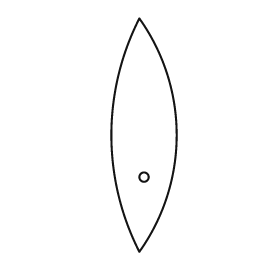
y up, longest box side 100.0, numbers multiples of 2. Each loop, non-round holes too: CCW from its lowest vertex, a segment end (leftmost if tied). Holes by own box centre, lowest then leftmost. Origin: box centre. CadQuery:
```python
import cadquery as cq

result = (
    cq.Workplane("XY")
    .moveTo(-2.0, -50.0)
    .threePointArc((14.0, 0.0), (-2.0, 50.0))
    .threePointArc((-14.0, 0.0), (-2.0, -50.0))
    .close()
    .moveTo(0.0, -18.0)
    .circle(2.0)
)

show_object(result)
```